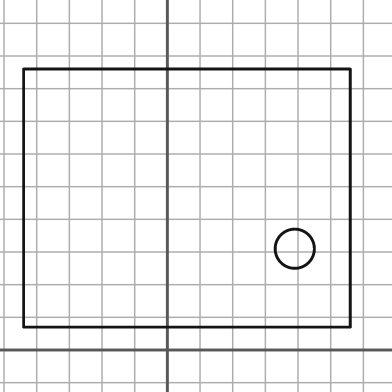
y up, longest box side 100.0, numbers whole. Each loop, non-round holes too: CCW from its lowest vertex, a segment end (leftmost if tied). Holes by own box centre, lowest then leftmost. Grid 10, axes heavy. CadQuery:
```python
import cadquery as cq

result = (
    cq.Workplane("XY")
    .moveTo(-44.0, 7.0)
    .lineTo(56.0, 7.0)
    .lineTo(56.0, 86.0)
    .lineTo(-44.0, 86.0)
    .close()
    .moveTo(39.0, 31.0)
    .circle(6.0)
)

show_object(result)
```